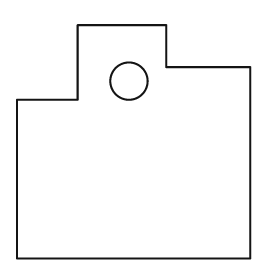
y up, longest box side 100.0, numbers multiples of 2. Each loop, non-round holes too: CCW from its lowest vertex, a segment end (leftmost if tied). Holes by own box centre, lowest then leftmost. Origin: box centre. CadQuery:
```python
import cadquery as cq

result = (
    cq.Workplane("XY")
    .moveTo(-50.0, -50.0)
    .lineTo(50.0, -50.0)
    .lineTo(50.0, 32.0)
    .lineTo(14.0, 32.0)
    .lineTo(14.0, 50.0)
    .lineTo(-24.0, 50.0)
    .lineTo(-24.0, 18.0)
    .lineTo(-50.0, 18.0)
    .close()
    .moveTo(-2.0, 26.0)
    .circle(8.0)
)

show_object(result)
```